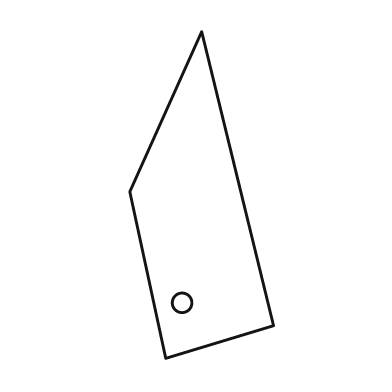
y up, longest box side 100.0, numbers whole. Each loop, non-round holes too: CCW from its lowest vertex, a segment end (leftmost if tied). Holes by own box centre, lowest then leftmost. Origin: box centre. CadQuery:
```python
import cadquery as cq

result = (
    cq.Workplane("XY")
    .moveTo(-11.0, -50.0)
    .lineTo(22.0, -40.0)
    .lineTo(0.0, 50.0)
    .lineTo(-22.0, 1.0)
    .close()
    .moveTo(-6.0, -33.0)
    .circle(3.0)
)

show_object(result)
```